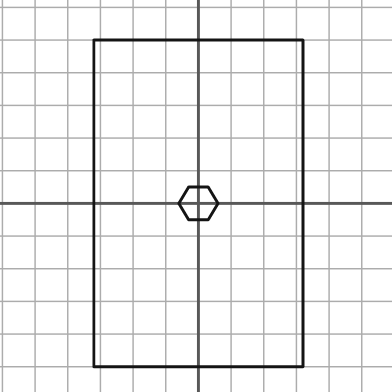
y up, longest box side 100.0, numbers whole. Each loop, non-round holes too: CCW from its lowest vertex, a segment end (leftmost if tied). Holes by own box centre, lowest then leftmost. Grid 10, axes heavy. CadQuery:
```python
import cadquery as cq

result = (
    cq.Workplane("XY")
    .moveTo(-32.0, -50.0)
    .lineTo(32.0, -50.0)
    .lineTo(32.0, 50.0)
    .lineTo(-32.0, 50.0)
    .close()
    .moveTo(-3.0, -5.0)
    .lineTo(3.0, -5.0)
    .lineTo(6.0, 0.0)
    .lineTo(3.0, 5.0)
    .lineTo(-3.0, 5.0)
    .lineTo(-6.0, 0.0)
    .close()
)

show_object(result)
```